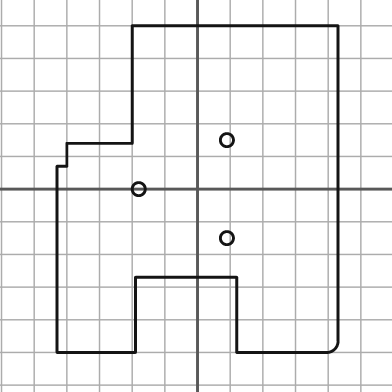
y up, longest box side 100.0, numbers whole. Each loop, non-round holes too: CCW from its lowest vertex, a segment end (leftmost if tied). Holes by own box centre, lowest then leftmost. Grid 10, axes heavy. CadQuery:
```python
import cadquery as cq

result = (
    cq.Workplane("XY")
    .moveTo(-43.0, -50.0)
    .lineTo(-19.0, -50.0)
    .lineTo(-19.0, -27.0)
    .lineTo(12.0, -27.0)
    .lineTo(12.0, -50.0)
    .lineTo(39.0, -50.0)
    .threePointArc((42.0, -49.0), (43.0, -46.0))
    .lineTo(43.0, 50.0)
    .lineTo(-20.0, 50.0)
    .lineTo(-20.0, 14.0)
    .lineTo(-40.0, 14.0)
    .lineTo(-40.0, 7.0)
    .lineTo(-43.0, 7.0)
    .close()
    .moveTo(9.0, -15.0)
    .circle(2.0)
    .moveTo(-18.0, 0.0)
    .circle(2.0)
    .moveTo(9.0, 15.0)
    .circle(2.0)
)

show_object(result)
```